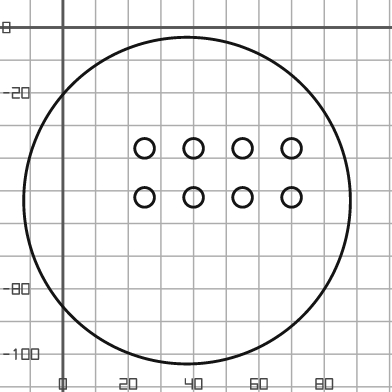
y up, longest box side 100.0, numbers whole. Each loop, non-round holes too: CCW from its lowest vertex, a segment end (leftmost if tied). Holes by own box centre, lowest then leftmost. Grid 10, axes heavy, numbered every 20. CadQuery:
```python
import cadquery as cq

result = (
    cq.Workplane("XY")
    .moveTo(38.0, -53.0)
    .circle(50.0)
    .moveTo(25.0, -52.0)
    .circle(3.0)
    .moveTo(40.0, -52.0)
    .circle(3.0)
    .moveTo(55.0, -52.0)
    .circle(3.0)
    .moveTo(70.0, -52.0)
    .circle(3.0)
    .moveTo(25.0, -37.0)
    .circle(3.0)
    .moveTo(40.0, -37.0)
    .circle(3.0)
    .moveTo(55.0, -37.0)
    .circle(3.0)
    .moveTo(70.0, -37.0)
    .circle(3.0)
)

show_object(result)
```